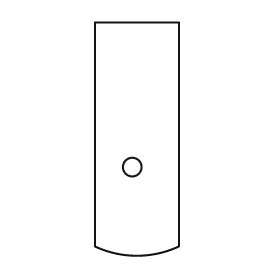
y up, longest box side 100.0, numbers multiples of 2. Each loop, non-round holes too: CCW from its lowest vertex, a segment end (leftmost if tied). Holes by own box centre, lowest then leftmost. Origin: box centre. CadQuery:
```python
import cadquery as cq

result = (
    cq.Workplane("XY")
    .moveTo(-18.0, -46.0)
    .threePointArc((0.0, -50.0), (18.0, -46.0))
    .lineTo(18.0, 50.0)
    .lineTo(-18.0, 50.0)
    .close()
    .moveTo(-2.0, -12.0)
    .circle(4.0)
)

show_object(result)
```